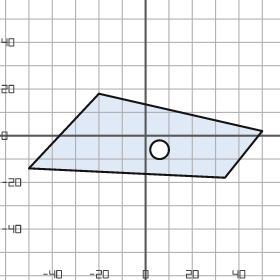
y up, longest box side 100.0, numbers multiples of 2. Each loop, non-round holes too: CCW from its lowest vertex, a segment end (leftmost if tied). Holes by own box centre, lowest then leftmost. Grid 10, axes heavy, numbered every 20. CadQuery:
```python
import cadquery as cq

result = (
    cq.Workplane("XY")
    .moveTo(34.0, -18.0)
    .lineTo(50.0, 2.0)
    .lineTo(-20.0, 18.0)
    .lineTo(-50.0, -14.0)
    .close()
    .moveTo(6.0, -6.0)
    .circle(4.0)
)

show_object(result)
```